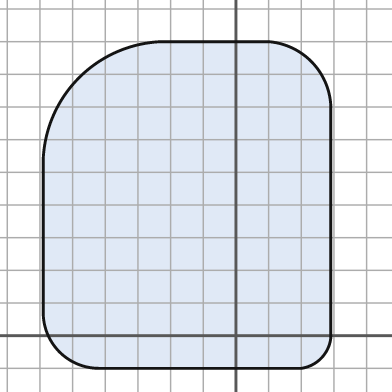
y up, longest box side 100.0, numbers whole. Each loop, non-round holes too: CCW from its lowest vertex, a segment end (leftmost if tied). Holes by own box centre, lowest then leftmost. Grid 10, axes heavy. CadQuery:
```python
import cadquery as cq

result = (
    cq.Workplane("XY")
    .moveTo(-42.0, -10.0)
    .lineTo(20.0, -10.0)
    .threePointArc((26.0, -7.0), (29.0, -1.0))
    .lineTo(29.0, 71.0)
    .threePointArc((23.0, 84.0), (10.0, 90.0))
    .lineTo(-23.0, 90.0)
    .threePointArc((-48.0, 79.0), (-59.0, 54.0))
    .lineTo(-59.0, 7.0)
    .threePointArc((-54.0, -5.0), (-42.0, -10.0))
    .close()
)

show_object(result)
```